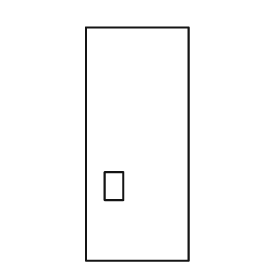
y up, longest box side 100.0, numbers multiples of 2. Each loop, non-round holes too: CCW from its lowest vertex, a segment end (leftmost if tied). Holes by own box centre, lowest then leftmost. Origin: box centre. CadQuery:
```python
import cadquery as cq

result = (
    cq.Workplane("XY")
    .moveTo(-22.0, -50.0)
    .lineTo(22.0, -50.0)
    .lineTo(22.0, 50.0)
    .lineTo(-22.0, 50.0)
    .close()
    .moveTo(-14.0, -24.0)
    .lineTo(-6.0, -24.0)
    .lineTo(-6.0, -12.0)
    .lineTo(-14.0, -12.0)
    .close()
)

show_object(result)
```